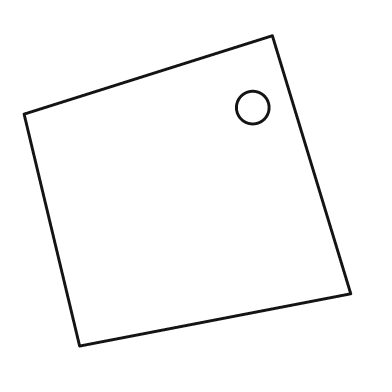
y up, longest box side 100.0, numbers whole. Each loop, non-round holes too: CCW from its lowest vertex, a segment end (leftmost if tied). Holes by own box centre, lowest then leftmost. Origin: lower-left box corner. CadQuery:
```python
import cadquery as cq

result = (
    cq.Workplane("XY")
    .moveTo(17.0, 0.0)
    .lineTo(100.0, 16.0)
    .lineTo(76.0, 95.0)
    .lineTo(0.0, 71.0)
    .close()
    .moveTo(70.0, 73.0)
    .circle(5.0)
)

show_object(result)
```